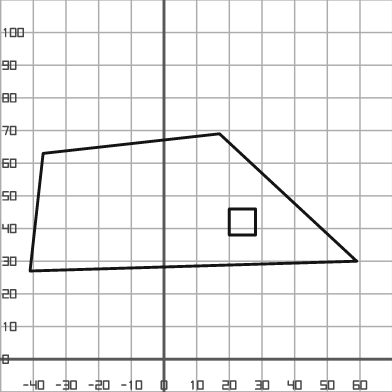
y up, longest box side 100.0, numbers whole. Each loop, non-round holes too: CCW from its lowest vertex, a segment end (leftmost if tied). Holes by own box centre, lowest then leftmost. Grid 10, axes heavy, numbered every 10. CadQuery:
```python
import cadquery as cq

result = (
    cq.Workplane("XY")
    .moveTo(-41.0, 27.0)
    .lineTo(59.0, 30.0)
    .lineTo(17.0, 69.0)
    .lineTo(-37.0, 63.0)
    .close()
    .moveTo(20.0, 38.0)
    .lineTo(28.0, 38.0)
    .lineTo(28.0, 46.0)
    .lineTo(20.0, 46.0)
    .close()
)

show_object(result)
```